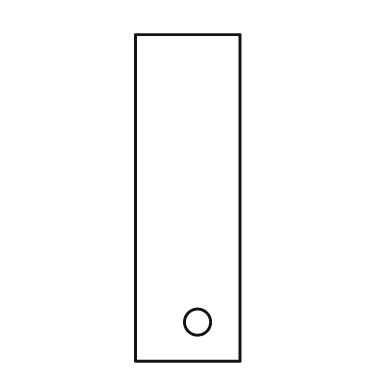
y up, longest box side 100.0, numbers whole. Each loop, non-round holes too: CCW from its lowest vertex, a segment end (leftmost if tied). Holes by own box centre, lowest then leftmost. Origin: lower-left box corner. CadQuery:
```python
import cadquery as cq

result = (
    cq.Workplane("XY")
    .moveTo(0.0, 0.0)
    .lineTo(32.0, 0.0)
    .lineTo(32.0, 100.0)
    .lineTo(0.0, 100.0)
    .close()
    .moveTo(19.0, 12.0)
    .circle(4.0)
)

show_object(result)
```